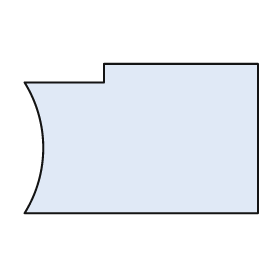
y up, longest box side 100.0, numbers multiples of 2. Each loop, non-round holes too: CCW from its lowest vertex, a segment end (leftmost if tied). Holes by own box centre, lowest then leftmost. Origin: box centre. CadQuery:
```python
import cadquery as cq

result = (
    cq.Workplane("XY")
    .moveTo(-50.0, -32.0)
    .lineTo(50.0, -32.0)
    .lineTo(50.0, 32.0)
    .lineTo(-16.0, 32.0)
    .lineTo(-16.0, 24.0)
    .lineTo(-50.0, 24.0)
    .threePointArc((-42.0, -4.0), (-50.0, -32.0))
    .close()
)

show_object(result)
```